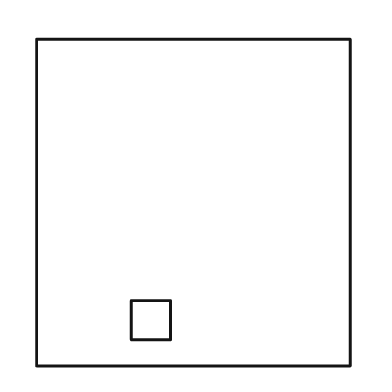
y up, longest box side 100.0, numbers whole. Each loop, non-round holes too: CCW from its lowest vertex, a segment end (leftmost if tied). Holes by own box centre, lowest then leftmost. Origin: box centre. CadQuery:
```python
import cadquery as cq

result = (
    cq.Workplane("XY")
    .moveTo(-48.0, -50.0)
    .lineTo(48.0, -50.0)
    .lineTo(48.0, 50.0)
    .lineTo(-48.0, 50.0)
    .close()
    .moveTo(-19.0, -42.0)
    .lineTo(-7.0, -42.0)
    .lineTo(-7.0, -30.0)
    .lineTo(-19.0, -30.0)
    .close()
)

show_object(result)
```